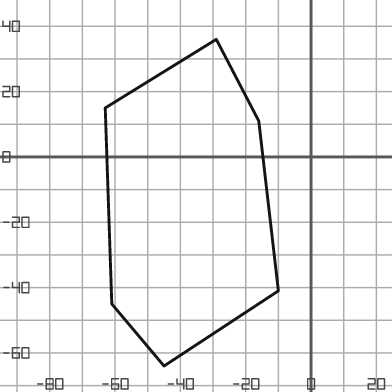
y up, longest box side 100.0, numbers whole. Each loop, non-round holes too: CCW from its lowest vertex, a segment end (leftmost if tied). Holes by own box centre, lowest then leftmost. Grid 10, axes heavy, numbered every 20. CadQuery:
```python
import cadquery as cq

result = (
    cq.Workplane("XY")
    .moveTo(-45.0, -64.0)
    .lineTo(-10.0, -41.0)
    .lineTo(-16.0, 11.0)
    .lineTo(-29.0, 36.0)
    .lineTo(-63.0, 15.0)
    .lineTo(-61.0, -45.0)
    .close()
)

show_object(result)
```